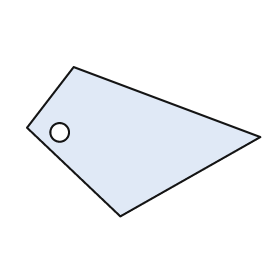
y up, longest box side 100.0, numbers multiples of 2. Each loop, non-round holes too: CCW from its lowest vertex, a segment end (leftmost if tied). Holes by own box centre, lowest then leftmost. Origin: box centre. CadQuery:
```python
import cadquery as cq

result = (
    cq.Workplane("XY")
    .moveTo(-10.0, -32.0)
    .lineTo(50.0, 2.0)
    .lineTo(-30.0, 32.0)
    .lineTo(-50.0, 6.0)
    .close()
    .moveTo(-36.0, 4.0)
    .circle(4.0)
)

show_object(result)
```